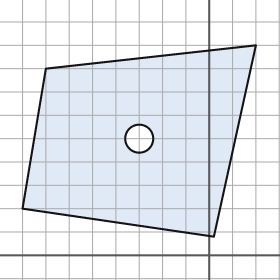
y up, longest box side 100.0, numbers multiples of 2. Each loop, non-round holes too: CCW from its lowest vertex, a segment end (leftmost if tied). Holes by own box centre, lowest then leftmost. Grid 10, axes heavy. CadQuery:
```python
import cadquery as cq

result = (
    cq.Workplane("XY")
    .moveTo(2.0, 8.0)
    .lineTo(20.0, 90.0)
    .lineTo(-70.0, 80.0)
    .lineTo(-80.0, 20.0)
    .close()
    .moveTo(-30.0, 50.0)
    .circle(6.0)
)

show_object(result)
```